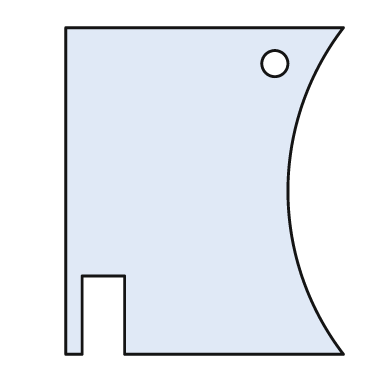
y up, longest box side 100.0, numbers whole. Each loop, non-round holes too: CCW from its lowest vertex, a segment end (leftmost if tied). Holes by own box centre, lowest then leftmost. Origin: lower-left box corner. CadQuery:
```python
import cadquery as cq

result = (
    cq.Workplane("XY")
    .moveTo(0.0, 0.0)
    .lineTo(5.0, 0.0)
    .lineTo(5.0, 24.0)
    .lineTo(18.0, 24.0)
    .lineTo(18.0, 0.0)
    .lineTo(85.0, 0.0)
    .threePointArc((68.0, 50.0), (85.0, 100.0))
    .lineTo(0.0, 100.0)
    .close()
    .moveTo(64.0, 89.0)
    .circle(4.0)
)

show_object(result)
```